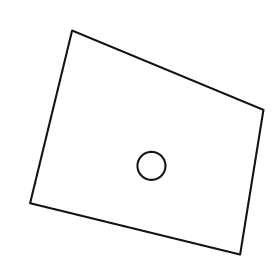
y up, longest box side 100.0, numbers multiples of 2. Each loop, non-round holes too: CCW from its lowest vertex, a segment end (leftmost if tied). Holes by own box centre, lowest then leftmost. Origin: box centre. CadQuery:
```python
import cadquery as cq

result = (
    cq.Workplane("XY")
    .moveTo(40.0, -48.0)
    .lineTo(50.0, 14.0)
    .lineTo(-32.0, 48.0)
    .lineTo(-50.0, -26.0)
    .close()
    .moveTo(2.0, -10.0)
    .circle(6.0)
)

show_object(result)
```